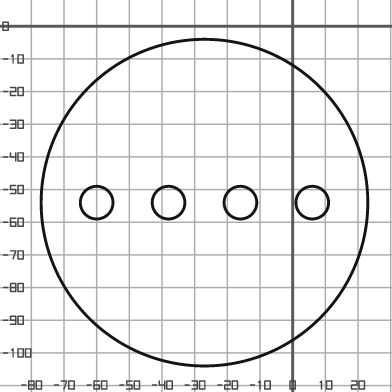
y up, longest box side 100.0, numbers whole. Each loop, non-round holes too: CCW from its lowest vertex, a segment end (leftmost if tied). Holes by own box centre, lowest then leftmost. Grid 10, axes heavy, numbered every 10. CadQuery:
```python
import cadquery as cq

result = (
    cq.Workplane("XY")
    .moveTo(-27.0, -54.0)
    .circle(50.0)
    .moveTo(-60.0, -54.0)
    .circle(5.0)
    .moveTo(-38.0, -54.0)
    .circle(5.0)
    .moveTo(-16.0, -54.0)
    .circle(5.0)
    .moveTo(6.0, -54.0)
    .circle(5.0)
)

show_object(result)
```